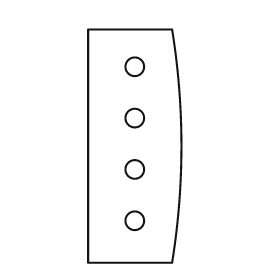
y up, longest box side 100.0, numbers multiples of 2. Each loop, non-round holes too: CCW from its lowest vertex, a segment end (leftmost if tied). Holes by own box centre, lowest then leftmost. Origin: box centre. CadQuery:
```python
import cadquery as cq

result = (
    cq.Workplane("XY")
    .moveTo(-20.0, -50.0)
    .lineTo(16.0, -50.0)
    .threePointArc((20.0, 0.0), (16.0, 50.0))
    .lineTo(-20.0, 50.0)
    .close()
    .moveTo(0.0, -32.0)
    .circle(4.0)
    .moveTo(0.0, -10.0)
    .circle(4.0)
    .moveTo(0.0, 12.0)
    .circle(4.0)
    .moveTo(0.0, 34.0)
    .circle(4.0)
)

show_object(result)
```